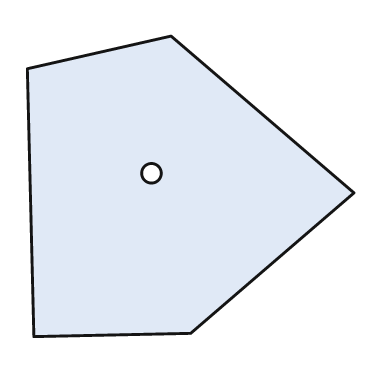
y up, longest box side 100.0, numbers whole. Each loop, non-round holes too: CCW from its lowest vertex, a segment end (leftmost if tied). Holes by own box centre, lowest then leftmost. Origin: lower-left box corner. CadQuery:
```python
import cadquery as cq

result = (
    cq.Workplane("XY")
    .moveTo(2.0, 0.0)
    .lineTo(50.0, 1.0)
    .lineTo(100.0, 44.0)
    .lineTo(44.0, 92.0)
    .lineTo(0.0, 82.0)
    .close()
    .moveTo(38.0, 50.0)
    .circle(3.0)
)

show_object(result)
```